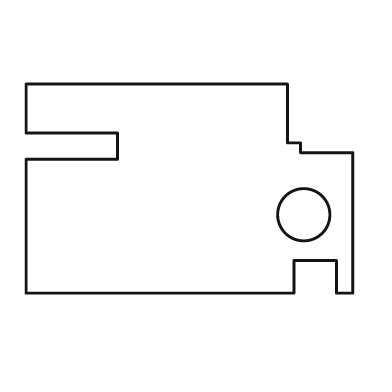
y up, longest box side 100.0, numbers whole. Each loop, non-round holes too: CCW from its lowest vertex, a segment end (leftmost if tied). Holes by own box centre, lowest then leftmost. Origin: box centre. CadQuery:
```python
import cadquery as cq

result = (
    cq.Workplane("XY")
    .moveTo(-50.0, -32.0)
    .lineTo(32.0, -32.0)
    .lineTo(32.0, -22.0)
    .lineTo(45.0, -22.0)
    .lineTo(45.0, -32.0)
    .lineTo(50.0, -32.0)
    .lineTo(50.0, 11.0)
    .lineTo(34.0, 11.0)
    .lineTo(34.0, 14.0)
    .lineTo(30.0, 14.0)
    .lineTo(30.0, 32.0)
    .lineTo(-50.0, 32.0)
    .lineTo(-50.0, 17.0)
    .lineTo(-22.0, 17.0)
    .lineTo(-22.0, 9.0)
    .lineTo(-50.0, 9.0)
    .close()
    .moveTo(35.0, -8.0)
    .circle(8.0)
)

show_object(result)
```